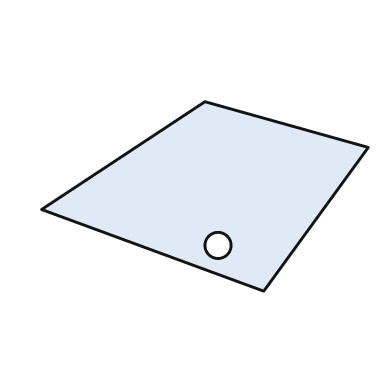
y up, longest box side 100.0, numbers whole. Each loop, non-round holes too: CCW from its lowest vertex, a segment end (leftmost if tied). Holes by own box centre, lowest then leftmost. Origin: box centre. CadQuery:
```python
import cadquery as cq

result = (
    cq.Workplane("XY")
    .moveTo(18.0, -29.0)
    .lineTo(50.0, 15.0)
    .lineTo(0.0, 29.0)
    .lineTo(-50.0, -4.0)
    .close()
    .moveTo(4.0, -15.0)
    .circle(4.0)
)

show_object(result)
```